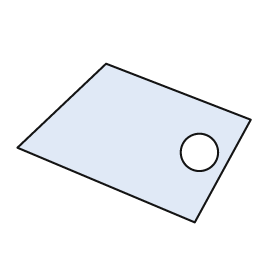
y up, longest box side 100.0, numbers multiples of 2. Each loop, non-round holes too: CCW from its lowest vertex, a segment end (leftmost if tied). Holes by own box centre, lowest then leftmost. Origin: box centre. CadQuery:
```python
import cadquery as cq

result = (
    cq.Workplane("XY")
    .moveTo(26.0, -34.0)
    .lineTo(50.0, 10.0)
    .lineTo(-12.0, 34.0)
    .lineTo(-50.0, -2.0)
    .close()
    .moveTo(28.0, -4.0)
    .circle(8.0)
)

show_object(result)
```